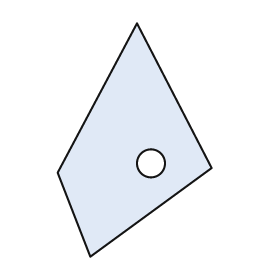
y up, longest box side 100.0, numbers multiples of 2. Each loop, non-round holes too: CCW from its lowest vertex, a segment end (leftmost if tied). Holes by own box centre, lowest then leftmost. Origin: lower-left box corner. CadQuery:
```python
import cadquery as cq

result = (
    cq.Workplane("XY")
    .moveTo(14.0, 0.0)
    .lineTo(66.0, 38.0)
    .lineTo(34.0, 100.0)
    .lineTo(0.0, 36.0)
    .close()
    .moveTo(40.0, 40.0)
    .circle(6.0)
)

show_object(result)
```